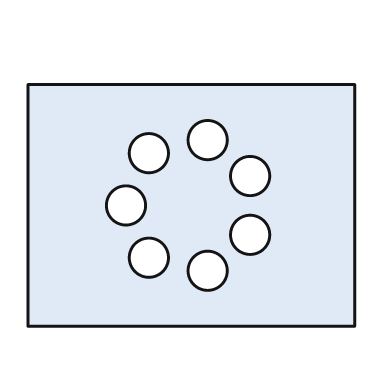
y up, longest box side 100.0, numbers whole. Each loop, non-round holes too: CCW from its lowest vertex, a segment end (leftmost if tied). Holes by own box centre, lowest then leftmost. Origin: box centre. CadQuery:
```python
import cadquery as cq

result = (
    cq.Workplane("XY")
    .moveTo(-50.0, -37.0)
    .lineTo(50.0, -37.0)
    .lineTo(50.0, 37.0)
    .lineTo(-50.0, 37.0)
    .close()
    .moveTo(5.0, -20.0)
    .circle(6.0)
    .moveTo(-13.0, -16.0)
    .circle(6.0)
    .moveTo(18.0, -9.0)
    .circle(6.0)
    .moveTo(-20.0, 0.0)
    .circle(6.0)
    .moveTo(18.0, 9.0)
    .circle(6.0)
    .moveTo(-13.0, 16.0)
    .circle(6.0)
    .moveTo(5.0, 20.0)
    .circle(6.0)
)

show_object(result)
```